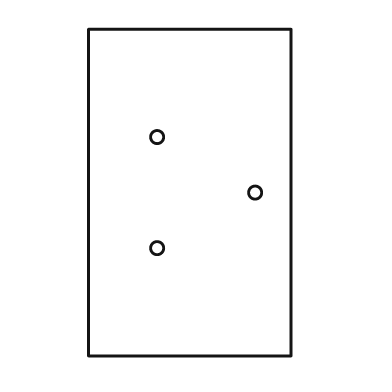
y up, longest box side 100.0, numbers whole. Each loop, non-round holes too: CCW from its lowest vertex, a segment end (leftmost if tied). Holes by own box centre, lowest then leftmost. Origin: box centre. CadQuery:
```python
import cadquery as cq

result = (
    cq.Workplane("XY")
    .moveTo(-31.0, -50.0)
    .lineTo(31.0, -50.0)
    .lineTo(31.0, 50.0)
    .lineTo(-31.0, 50.0)
    .close()
    .moveTo(-10.0, -17.0)
    .circle(2.0)
    .moveTo(20.0, 0.0)
    .circle(2.0)
    .moveTo(-10.0, 17.0)
    .circle(2.0)
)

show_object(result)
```